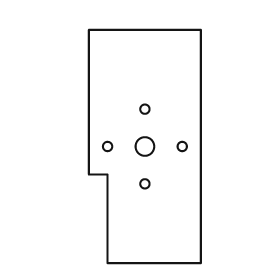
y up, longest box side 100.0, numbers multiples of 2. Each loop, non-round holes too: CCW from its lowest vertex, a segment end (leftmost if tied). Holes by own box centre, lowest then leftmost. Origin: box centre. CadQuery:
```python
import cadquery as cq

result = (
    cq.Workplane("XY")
    .moveTo(-16.0, -50.0)
    .lineTo(24.0, -50.0)
    .lineTo(24.0, 50.0)
    .lineTo(-24.0, 50.0)
    .lineTo(-24.0, -12.0)
    .lineTo(-16.0, -12.0)
    .close()
    .moveTo(0.0, -16.0)
    .circle(2.0)
    .moveTo(-16.0, 0.0)
    .circle(2.0)
    .moveTo(0.0, 0.0)
    .circle(4.0)
    .moveTo(16.0, 0.0)
    .circle(2.0)
    .moveTo(0.0, 16.0)
    .circle(2.0)
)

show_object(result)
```